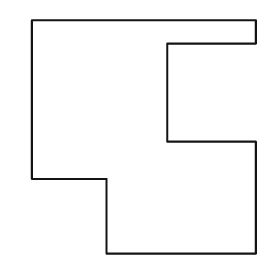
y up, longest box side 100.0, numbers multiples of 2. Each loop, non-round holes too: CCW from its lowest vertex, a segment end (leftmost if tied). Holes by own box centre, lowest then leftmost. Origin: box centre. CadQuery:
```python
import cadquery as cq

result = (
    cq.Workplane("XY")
    .moveTo(-16.0, -50.0)
    .lineTo(48.0, -50.0)
    .lineTo(48.0, -2.0)
    .lineTo(10.0, -2.0)
    .lineTo(10.0, 40.0)
    .lineTo(48.0, 40.0)
    .lineTo(48.0, 50.0)
    .lineTo(-48.0, 50.0)
    .lineTo(-48.0, -18.0)
    .lineTo(-16.0, -18.0)
    .close()
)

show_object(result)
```